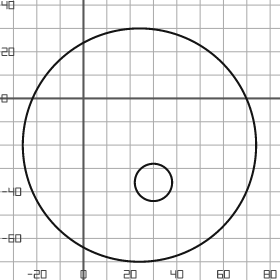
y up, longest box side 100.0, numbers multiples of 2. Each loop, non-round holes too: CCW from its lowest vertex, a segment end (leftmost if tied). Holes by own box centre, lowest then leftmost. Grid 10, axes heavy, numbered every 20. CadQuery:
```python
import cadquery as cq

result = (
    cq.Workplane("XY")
    .moveTo(24.0, -20.0)
    .circle(50.0)
    .moveTo(30.0, -36.0)
    .circle(8.0)
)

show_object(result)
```